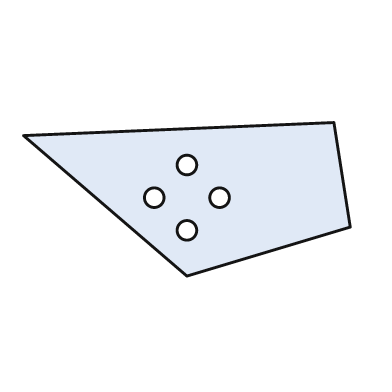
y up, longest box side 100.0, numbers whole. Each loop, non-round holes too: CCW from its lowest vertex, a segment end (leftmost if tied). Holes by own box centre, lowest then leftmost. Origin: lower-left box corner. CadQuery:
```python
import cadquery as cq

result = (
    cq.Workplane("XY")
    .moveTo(50.0, 0.0)
    .lineTo(100.0, 15.0)
    .lineTo(95.0, 47.0)
    .lineTo(0.0, 43.0)
    .close()
    .moveTo(50.0, 14.0)
    .circle(3.0)
    .moveTo(40.0, 24.0)
    .circle(3.0)
    .moveTo(60.0, 24.0)
    .circle(3.0)
    .moveTo(50.0, 34.0)
    .circle(3.0)
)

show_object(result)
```